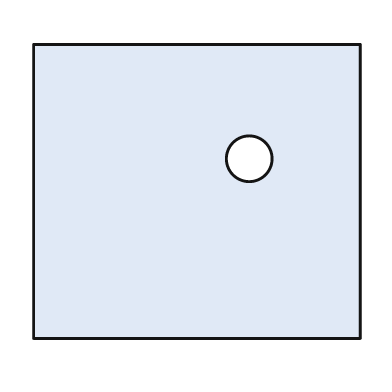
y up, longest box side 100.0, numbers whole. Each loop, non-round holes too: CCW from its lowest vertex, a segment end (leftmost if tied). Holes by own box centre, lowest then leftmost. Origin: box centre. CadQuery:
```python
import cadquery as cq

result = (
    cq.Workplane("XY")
    .moveTo(-50.0, -45.0)
    .lineTo(50.0, -45.0)
    .lineTo(50.0, 45.0)
    .lineTo(-50.0, 45.0)
    .close()
    .moveTo(16.0, 10.0)
    .circle(7.0)
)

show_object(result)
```